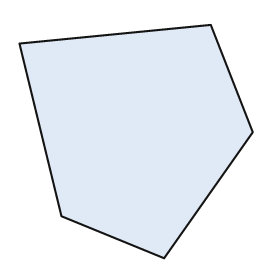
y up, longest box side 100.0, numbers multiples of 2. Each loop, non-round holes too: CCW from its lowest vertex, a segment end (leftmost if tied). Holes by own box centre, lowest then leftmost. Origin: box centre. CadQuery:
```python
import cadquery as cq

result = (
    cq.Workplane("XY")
    .moveTo(12.0, -50.0)
    .lineTo(50.0, 4.0)
    .lineTo(32.0, 50.0)
    .lineTo(-50.0, 42.0)
    .lineTo(-32.0, -32.0)
    .close()
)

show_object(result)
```